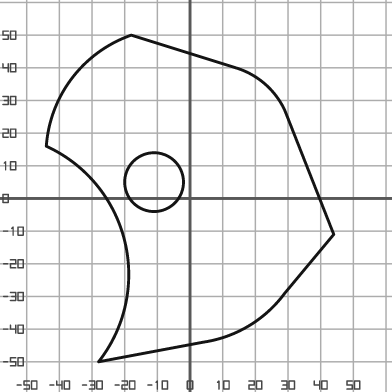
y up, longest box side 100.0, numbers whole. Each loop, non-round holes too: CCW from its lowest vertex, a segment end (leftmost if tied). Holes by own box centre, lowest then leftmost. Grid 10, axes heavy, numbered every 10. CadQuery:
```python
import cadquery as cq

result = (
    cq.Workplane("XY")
    .moveTo(-28.0, -50.0)
    .lineTo(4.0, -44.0)
    .threePointArc((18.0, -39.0), (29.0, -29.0))
    .lineTo(44.0, -11.0)
    .lineTo(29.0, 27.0)
    .threePointArc((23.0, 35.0), (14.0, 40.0))
    .lineTo(-18.0, 50.0)
    .threePointArc((-36.0, 37.0), (-44.0, 16.0))
    .threePointArc((-20.0, -13.0), (-28.0, -50.0))
    .close()
    .moveTo(-11.0, 5.0)
    .circle(9.0)
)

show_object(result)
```